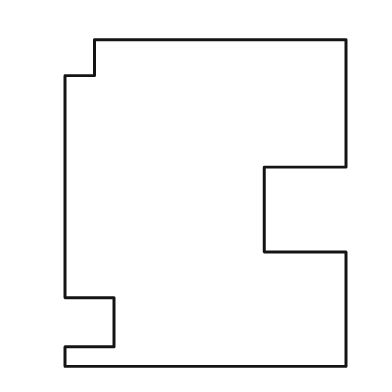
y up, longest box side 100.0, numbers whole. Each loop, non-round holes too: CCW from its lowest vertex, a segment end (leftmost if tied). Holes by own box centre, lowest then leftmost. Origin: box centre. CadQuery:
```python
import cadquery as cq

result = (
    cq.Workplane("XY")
    .moveTo(-43.0, -50.0)
    .lineTo(43.0, -50.0)
    .lineTo(43.0, -15.0)
    .lineTo(18.0, -15.0)
    .lineTo(18.0, 11.0)
    .lineTo(43.0, 11.0)
    .lineTo(43.0, 50.0)
    .lineTo(-34.0, 50.0)
    .lineTo(-34.0, 39.0)
    .lineTo(-43.0, 39.0)
    .lineTo(-43.0, -29.0)
    .lineTo(-28.0, -29.0)
    .lineTo(-28.0, -44.0)
    .lineTo(-43.0, -44.0)
    .close()
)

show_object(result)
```